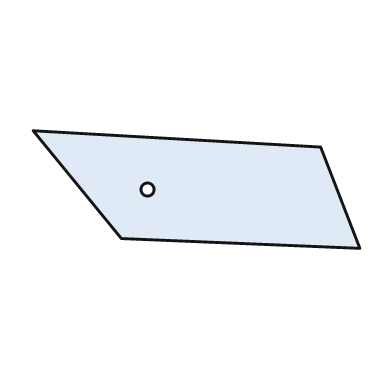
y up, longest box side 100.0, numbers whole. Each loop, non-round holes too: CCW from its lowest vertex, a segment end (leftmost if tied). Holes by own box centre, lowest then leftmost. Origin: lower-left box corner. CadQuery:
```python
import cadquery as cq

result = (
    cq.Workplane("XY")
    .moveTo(100.0, 0.0)
    .lineTo(88.0, 31.0)
    .lineTo(0.0, 36.0)
    .lineTo(27.0, 3.0)
    .close()
    .moveTo(35.0, 18.0)
    .circle(2.0)
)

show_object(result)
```